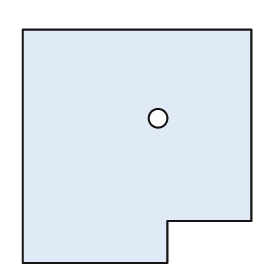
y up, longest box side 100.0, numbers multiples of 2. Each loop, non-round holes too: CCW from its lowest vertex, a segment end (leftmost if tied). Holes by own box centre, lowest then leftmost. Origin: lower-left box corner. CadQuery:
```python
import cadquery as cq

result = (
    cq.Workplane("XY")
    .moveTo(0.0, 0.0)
    .lineTo(62.0, 0.0)
    .lineTo(62.0, 18.0)
    .lineTo(98.0, 18.0)
    .lineTo(98.0, 100.0)
    .lineTo(0.0, 100.0)
    .close()
    .moveTo(58.0, 62.0)
    .circle(4.0)
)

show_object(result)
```